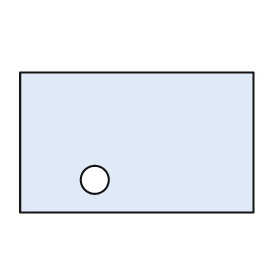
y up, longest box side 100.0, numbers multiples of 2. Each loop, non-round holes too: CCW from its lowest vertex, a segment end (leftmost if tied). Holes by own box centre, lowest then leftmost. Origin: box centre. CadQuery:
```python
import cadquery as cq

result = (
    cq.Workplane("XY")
    .moveTo(-50.0, -30.0)
    .lineTo(50.0, -30.0)
    .lineTo(50.0, 30.0)
    .lineTo(-50.0, 30.0)
    .close()
    .moveTo(-18.0, -16.0)
    .circle(6.0)
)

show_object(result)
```